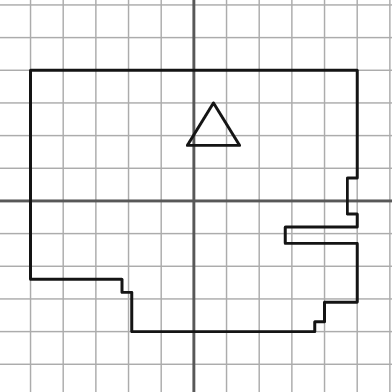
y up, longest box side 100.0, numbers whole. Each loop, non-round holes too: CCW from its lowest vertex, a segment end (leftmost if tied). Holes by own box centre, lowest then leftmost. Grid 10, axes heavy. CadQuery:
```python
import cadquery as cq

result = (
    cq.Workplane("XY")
    .moveTo(-19.0, -40.0)
    .lineTo(37.0, -40.0)
    .lineTo(37.0, -37.0)
    .lineTo(40.0, -37.0)
    .lineTo(40.0, -31.0)
    .lineTo(50.0, -31.0)
    .lineTo(50.0, -13.0)
    .lineTo(28.0, -13.0)
    .lineTo(28.0, -8.0)
    .lineTo(50.0, -8.0)
    .lineTo(50.0, -4.0)
    .lineTo(47.0, -4.0)
    .lineTo(47.0, 7.0)
    .lineTo(50.0, 7.0)
    .lineTo(50.0, 40.0)
    .lineTo(-50.0, 40.0)
    .lineTo(-50.0, -24.0)
    .lineTo(-22.0, -24.0)
    .lineTo(-22.0, -28.0)
    .lineTo(-19.0, -28.0)
    .close()
    .moveTo(-2.0, 17.0)
    .lineTo(14.0, 17.0)
    .lineTo(6.0, 30.0)
    .close()
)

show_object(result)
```